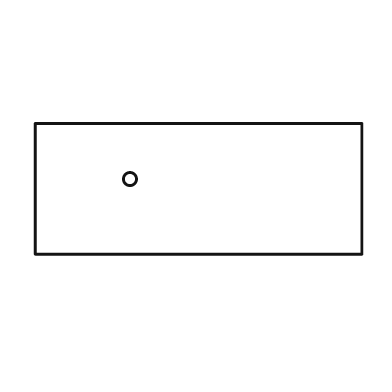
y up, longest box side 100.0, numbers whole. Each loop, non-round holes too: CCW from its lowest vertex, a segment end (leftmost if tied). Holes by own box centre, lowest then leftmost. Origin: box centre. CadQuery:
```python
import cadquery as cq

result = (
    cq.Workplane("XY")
    .moveTo(-50.0, -20.0)
    .lineTo(50.0, -20.0)
    .lineTo(50.0, 20.0)
    .lineTo(-50.0, 20.0)
    .close()
    .moveTo(-21.0, 3.0)
    .circle(2.0)
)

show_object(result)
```